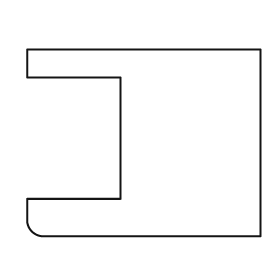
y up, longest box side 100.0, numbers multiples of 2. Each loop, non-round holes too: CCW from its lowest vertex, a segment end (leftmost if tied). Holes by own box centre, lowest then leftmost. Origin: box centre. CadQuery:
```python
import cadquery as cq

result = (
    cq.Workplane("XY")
    .moveTo(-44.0, -40.0)
    .lineTo(50.0, -40.0)
    .lineTo(50.0, 40.0)
    .lineTo(-50.0, 40.0)
    .lineTo(-50.0, 28.0)
    .lineTo(-10.0, 28.0)
    .lineTo(-10.0, -24.0)
    .lineTo(-50.0, -24.0)
    .lineTo(-50.0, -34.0)
    .threePointArc((-48.0, -38.0), (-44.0, -40.0))
    .close()
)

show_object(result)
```